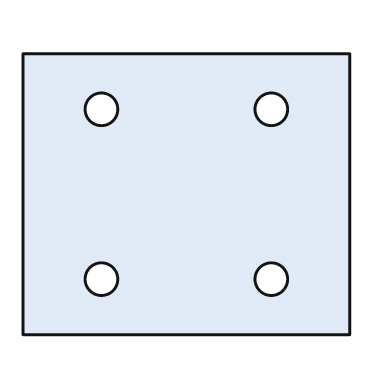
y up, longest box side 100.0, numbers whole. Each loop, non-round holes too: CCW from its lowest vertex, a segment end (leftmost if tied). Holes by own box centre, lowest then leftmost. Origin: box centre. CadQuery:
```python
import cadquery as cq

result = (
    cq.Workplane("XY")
    .moveTo(-50.0, -43.0)
    .lineTo(50.0, -43.0)
    .lineTo(50.0, 43.0)
    .lineTo(-50.0, 43.0)
    .close()
    .moveTo(-26.0, -26.0)
    .circle(5.0)
    .moveTo(26.0, -26.0)
    .circle(5.0)
    .moveTo(-26.0, 26.0)
    .circle(5.0)
    .moveTo(26.0, 26.0)
    .circle(5.0)
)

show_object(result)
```